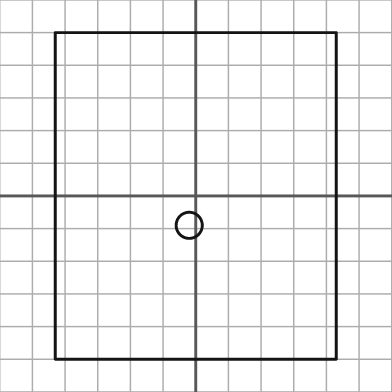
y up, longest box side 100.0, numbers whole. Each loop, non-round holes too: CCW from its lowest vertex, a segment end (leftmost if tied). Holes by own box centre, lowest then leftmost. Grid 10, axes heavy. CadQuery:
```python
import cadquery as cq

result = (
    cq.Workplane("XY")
    .moveTo(-43.0, -50.0)
    .lineTo(43.0, -50.0)
    .lineTo(43.0, 50.0)
    .lineTo(-43.0, 50.0)
    .close()
    .moveTo(-2.0, -9.0)
    .circle(4.0)
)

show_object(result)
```